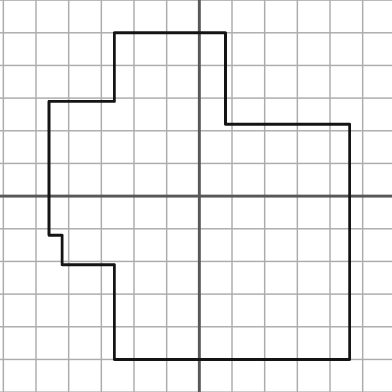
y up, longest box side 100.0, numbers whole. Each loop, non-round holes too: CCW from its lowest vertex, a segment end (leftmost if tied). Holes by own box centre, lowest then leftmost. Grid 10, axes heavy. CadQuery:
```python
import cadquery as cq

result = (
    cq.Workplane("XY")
    .moveTo(-26.0, -50.0)
    .lineTo(46.0, -50.0)
    .lineTo(46.0, 22.0)
    .lineTo(8.0, 22.0)
    .lineTo(8.0, 50.0)
    .lineTo(-26.0, 50.0)
    .lineTo(-26.0, 29.0)
    .lineTo(-46.0, 29.0)
    .lineTo(-46.0, -12.0)
    .lineTo(-42.0, -12.0)
    .lineTo(-42.0, -21.0)
    .lineTo(-26.0, -21.0)
    .close()
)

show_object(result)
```